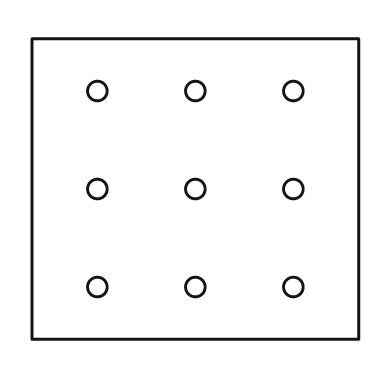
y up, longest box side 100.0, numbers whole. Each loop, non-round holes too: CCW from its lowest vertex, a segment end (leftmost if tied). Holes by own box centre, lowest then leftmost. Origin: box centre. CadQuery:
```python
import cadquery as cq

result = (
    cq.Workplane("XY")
    .moveTo(-50.0, -46.0)
    .lineTo(50.0, -46.0)
    .lineTo(50.0, 46.0)
    .lineTo(-50.0, 46.0)
    .close()
    .moveTo(-30.0, -30.0)
    .circle(3.0)
    .moveTo(0.0, -30.0)
    .circle(3.0)
    .moveTo(30.0, -30.0)
    .circle(3.0)
    .moveTo(-30.0, 0.0)
    .circle(3.0)
    .moveTo(0.0, 0.0)
    .circle(3.0)
    .moveTo(30.0, 0.0)
    .circle(3.0)
    .moveTo(-30.0, 30.0)
    .circle(3.0)
    .moveTo(0.0, 30.0)
    .circle(3.0)
    .moveTo(30.0, 30.0)
    .circle(3.0)
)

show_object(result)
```